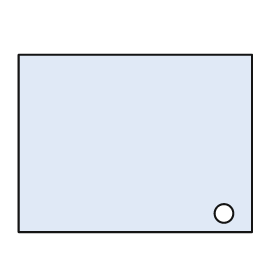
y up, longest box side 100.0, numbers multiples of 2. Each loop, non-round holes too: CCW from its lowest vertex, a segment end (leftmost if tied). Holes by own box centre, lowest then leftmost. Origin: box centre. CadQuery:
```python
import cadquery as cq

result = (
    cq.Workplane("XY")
    .moveTo(-50.0, -38.0)
    .lineTo(50.0, -38.0)
    .lineTo(50.0, 38.0)
    .lineTo(-50.0, 38.0)
    .close()
    .moveTo(38.0, -30.0)
    .circle(4.0)
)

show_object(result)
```